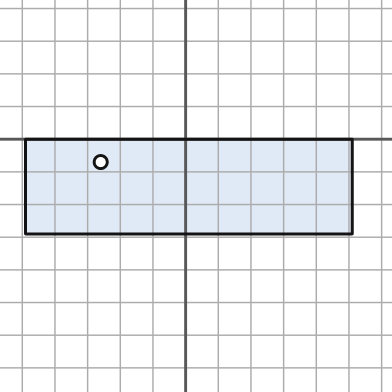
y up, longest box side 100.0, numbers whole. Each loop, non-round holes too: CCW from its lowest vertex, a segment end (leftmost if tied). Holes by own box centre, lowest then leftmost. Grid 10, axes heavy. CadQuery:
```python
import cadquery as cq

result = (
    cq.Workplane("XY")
    .moveTo(-49.0, -29.0)
    .lineTo(51.0, -29.0)
    .lineTo(51.0, 0.0)
    .lineTo(-49.0, 0.0)
    .close()
    .moveTo(-26.0, -7.0)
    .circle(2.0)
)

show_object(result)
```